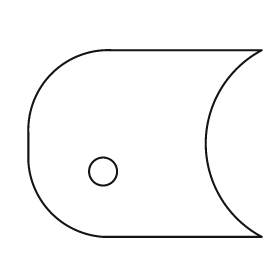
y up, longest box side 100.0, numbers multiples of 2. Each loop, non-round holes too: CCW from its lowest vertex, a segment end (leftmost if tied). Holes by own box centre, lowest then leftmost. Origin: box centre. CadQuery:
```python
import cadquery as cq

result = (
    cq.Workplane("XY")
    .moveTo(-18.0, -40.0)
    .lineTo(50.0, -40.0)
    .threePointArc((26.0, 0.0), (50.0, 40.0))
    .lineTo(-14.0, 40.0)
    .threePointArc((-40.0, 30.0), (-50.0, 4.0))
    .lineTo(-50.0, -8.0)
    .threePointArc((-40.0, -30.0), (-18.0, -40.0))
    .close()
    .moveTo(-18.0, -12.0)
    .circle(6.0)
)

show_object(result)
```